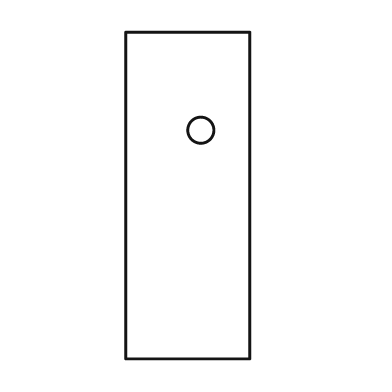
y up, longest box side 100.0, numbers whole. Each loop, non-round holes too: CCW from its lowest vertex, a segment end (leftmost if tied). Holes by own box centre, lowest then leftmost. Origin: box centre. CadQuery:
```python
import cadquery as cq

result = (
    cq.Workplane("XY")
    .moveTo(-19.0, -50.0)
    .lineTo(19.0, -50.0)
    .lineTo(19.0, 50.0)
    .lineTo(-19.0, 50.0)
    .close()
    .moveTo(4.0, 20.0)
    .circle(4.0)
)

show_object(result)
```